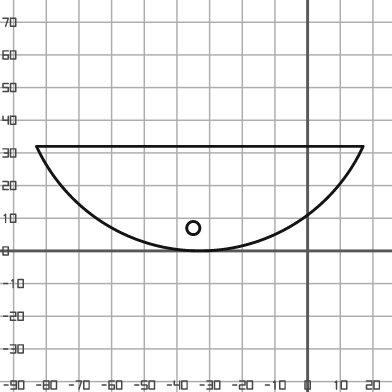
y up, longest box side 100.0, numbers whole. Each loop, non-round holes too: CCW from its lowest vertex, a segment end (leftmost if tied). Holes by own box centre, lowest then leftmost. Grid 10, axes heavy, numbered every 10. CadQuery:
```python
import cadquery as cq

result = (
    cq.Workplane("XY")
    .moveTo(-83.0, 32.0)
    .threePointArc((-33.0, 0.0), (17.0, 32.0))
    .close()
    .moveTo(-35.0, 7.0)
    .circle(2.0)
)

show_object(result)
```